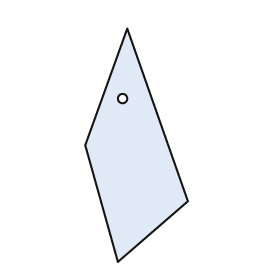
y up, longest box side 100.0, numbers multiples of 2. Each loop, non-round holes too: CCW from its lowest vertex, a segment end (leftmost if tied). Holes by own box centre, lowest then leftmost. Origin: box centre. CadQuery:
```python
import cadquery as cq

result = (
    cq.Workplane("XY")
    .moveTo(-8.0, -50.0)
    .lineTo(22.0, -24.0)
    .lineTo(-4.0, 50.0)
    .lineTo(-22.0, 0.0)
    .close()
    .moveTo(-6.0, 20.0)
    .circle(2.0)
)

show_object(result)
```